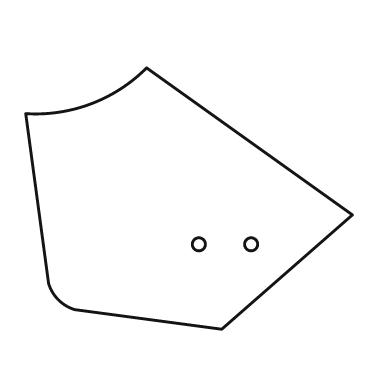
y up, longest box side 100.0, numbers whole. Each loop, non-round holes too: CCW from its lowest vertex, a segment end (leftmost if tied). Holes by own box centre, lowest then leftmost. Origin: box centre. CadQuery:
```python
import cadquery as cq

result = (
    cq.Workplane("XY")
    .moveTo(10.0, -40.0)
    .lineTo(50.0, -5.0)
    .lineTo(-13.0, 40.0)
    .threePointArc((-30.0, 29.0), (-50.0, 26.0))
    .lineTo(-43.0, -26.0)
    .threePointArc((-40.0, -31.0), (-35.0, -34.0))
    .close()
    .moveTo(3.0, -14.0)
    .circle(2.0)
    .moveTo(19.0, -14.0)
    .circle(2.0)
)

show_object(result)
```